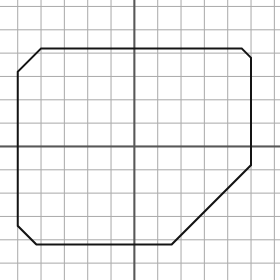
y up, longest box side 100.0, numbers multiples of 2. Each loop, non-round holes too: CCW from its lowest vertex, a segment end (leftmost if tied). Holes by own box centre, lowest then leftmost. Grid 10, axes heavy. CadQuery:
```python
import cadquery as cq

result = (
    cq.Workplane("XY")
    .moveTo(-42.0, -42.0)
    .lineTo(16.0, -42.0)
    .lineTo(50.0, -8.0)
    .lineTo(50.0, 38.0)
    .lineTo(46.0, 42.0)
    .lineTo(-40.0, 42.0)
    .lineTo(-50.0, 32.0)
    .lineTo(-50.0, -34.0)
    .close()
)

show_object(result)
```